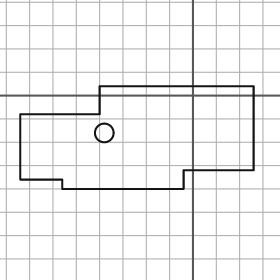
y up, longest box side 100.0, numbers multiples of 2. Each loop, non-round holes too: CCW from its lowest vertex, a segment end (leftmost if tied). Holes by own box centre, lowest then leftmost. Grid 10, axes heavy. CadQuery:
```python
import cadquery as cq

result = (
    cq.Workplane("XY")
    .moveTo(-56.0, -40.0)
    .lineTo(-4.0, -40.0)
    .lineTo(-4.0, -32.0)
    .lineTo(26.0, -32.0)
    .lineTo(26.0, 4.0)
    .lineTo(-40.0, 4.0)
    .lineTo(-40.0, -8.0)
    .lineTo(-74.0, -8.0)
    .lineTo(-74.0, -36.0)
    .lineTo(-56.0, -36.0)
    .close()
    .moveTo(-38.0, -16.0)
    .circle(4.0)
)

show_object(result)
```